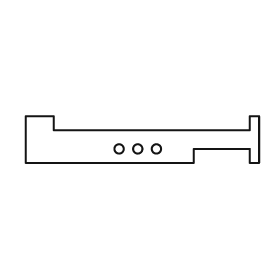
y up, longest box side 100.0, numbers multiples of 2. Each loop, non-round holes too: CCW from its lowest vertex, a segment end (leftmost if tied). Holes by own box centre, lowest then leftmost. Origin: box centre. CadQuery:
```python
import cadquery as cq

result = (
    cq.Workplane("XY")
    .moveTo(-50.0, -10.0)
    .lineTo(22.0, -10.0)
    .lineTo(22.0, -4.0)
    .lineTo(46.0, -4.0)
    .lineTo(46.0, -10.0)
    .lineTo(50.0, -10.0)
    .lineTo(50.0, 10.0)
    .lineTo(46.0, 10.0)
    .lineTo(46.0, 4.0)
    .lineTo(-38.0, 4.0)
    .lineTo(-38.0, 10.0)
    .lineTo(-50.0, 10.0)
    .close()
    .moveTo(-10.0, -4.0)
    .circle(2.0)
    .moveTo(-2.0, -4.0)
    .circle(2.0)
    .moveTo(6.0, -4.0)
    .circle(2.0)
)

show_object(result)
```